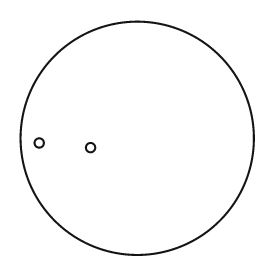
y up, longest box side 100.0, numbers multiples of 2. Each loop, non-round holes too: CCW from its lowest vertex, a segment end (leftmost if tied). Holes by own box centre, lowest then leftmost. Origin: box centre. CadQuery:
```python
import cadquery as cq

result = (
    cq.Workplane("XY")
    .moveTo(0.0, 0.0)
    .circle(50.0)
    .moveTo(-20.0, -4.0)
    .circle(2.0)
    .moveTo(-42.0, -2.0)
    .circle(2.0)
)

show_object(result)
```